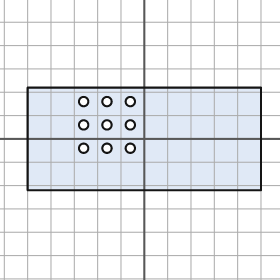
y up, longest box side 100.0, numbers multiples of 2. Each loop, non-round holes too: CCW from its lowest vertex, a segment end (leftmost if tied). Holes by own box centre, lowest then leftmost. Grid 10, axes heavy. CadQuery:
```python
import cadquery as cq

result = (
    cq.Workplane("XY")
    .moveTo(-50.0, -22.0)
    .lineTo(50.0, -22.0)
    .lineTo(50.0, 22.0)
    .lineTo(-50.0, 22.0)
    .close()
    .moveTo(-26.0, -4.0)
    .circle(2.0)
    .moveTo(-16.0, -4.0)
    .circle(2.0)
    .moveTo(-6.0, -4.0)
    .circle(2.0)
    .moveTo(-26.0, 6.0)
    .circle(2.0)
    .moveTo(-16.0, 6.0)
    .circle(2.0)
    .moveTo(-6.0, 6.0)
    .circle(2.0)
    .moveTo(-26.0, 16.0)
    .circle(2.0)
    .moveTo(-16.0, 16.0)
    .circle(2.0)
    .moveTo(-6.0, 16.0)
    .circle(2.0)
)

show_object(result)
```